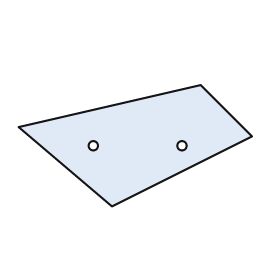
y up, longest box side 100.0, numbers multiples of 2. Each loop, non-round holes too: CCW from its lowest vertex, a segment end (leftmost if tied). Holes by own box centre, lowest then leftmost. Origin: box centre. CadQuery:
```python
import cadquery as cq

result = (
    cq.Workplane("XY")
    .moveTo(-10.0, -26.0)
    .lineTo(50.0, 4.0)
    .lineTo(28.0, 26.0)
    .lineTo(-50.0, 8.0)
    .close()
    .moveTo(-18.0, 0.0)
    .circle(2.0)
    .moveTo(20.0, 0.0)
    .circle(2.0)
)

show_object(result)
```